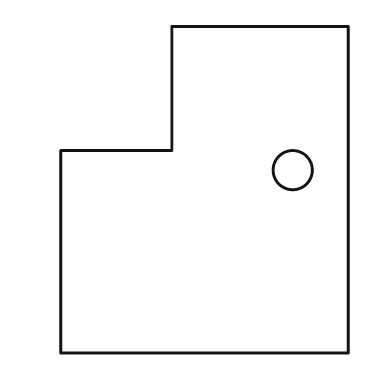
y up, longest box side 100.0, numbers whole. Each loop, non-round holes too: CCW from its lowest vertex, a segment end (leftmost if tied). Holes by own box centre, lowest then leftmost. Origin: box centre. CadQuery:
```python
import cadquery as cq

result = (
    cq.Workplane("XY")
    .moveTo(-44.0, -50.0)
    .lineTo(44.0, -50.0)
    .lineTo(44.0, 50.0)
    .lineTo(-10.0, 50.0)
    .lineTo(-10.0, 12.0)
    .lineTo(-44.0, 12.0)
    .close()
    .moveTo(27.0, 6.0)
    .circle(6.0)
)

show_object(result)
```